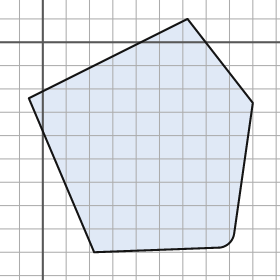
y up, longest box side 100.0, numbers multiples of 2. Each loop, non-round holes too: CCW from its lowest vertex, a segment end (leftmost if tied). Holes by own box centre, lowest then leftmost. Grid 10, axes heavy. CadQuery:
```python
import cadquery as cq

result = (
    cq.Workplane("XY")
    .moveTo(22.0, -90.0)
    .lineTo(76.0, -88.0)
    .threePointArc((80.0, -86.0), (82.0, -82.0))
    .lineTo(90.0, -26.0)
    .lineTo(62.0, 10.0)
    .lineTo(-6.0, -24.0)
    .close()
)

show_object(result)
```